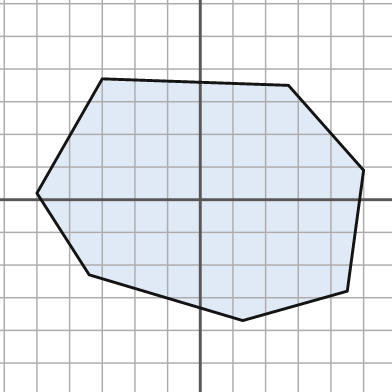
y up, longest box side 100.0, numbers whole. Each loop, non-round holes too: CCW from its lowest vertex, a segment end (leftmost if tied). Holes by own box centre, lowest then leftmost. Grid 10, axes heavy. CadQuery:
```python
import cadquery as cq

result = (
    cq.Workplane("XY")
    .moveTo(13.0, -37.0)
    .lineTo(45.0, -28.0)
    .lineTo(50.0, 9.0)
    .lineTo(27.0, 35.0)
    .lineTo(-30.0, 37.0)
    .lineTo(-50.0, 2.0)
    .lineTo(-34.0, -23.0)
    .close()
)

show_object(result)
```